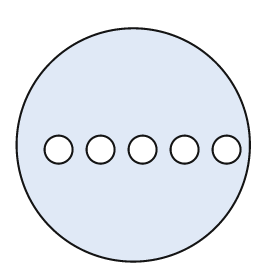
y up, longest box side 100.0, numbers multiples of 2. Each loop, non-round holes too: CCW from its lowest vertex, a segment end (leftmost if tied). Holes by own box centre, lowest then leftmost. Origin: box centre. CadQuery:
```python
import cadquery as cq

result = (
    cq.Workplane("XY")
    .moveTo(0.0, 0.0)
    .circle(50.0)
    .moveTo(-32.0, -2.0)
    .circle(6.0)
    .moveTo(-14.0, -2.0)
    .circle(6.0)
    .moveTo(4.0, -2.0)
    .circle(6.0)
    .moveTo(22.0, -2.0)
    .circle(6.0)
    .moveTo(40.0, -2.0)
    .circle(6.0)
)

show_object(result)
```